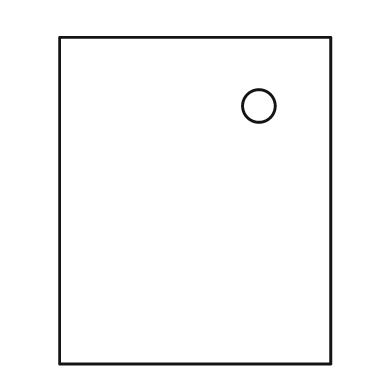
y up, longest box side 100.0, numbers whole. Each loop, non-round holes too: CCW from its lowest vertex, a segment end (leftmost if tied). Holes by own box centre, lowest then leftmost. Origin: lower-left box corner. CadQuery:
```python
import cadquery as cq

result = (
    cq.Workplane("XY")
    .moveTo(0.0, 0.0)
    .lineTo(83.0, 0.0)
    .lineTo(83.0, 100.0)
    .lineTo(0.0, 100.0)
    .close()
    .moveTo(61.0, 79.0)
    .circle(5.0)
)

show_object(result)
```